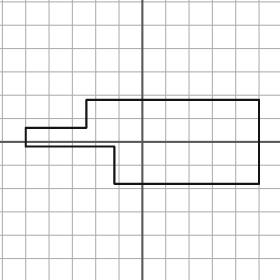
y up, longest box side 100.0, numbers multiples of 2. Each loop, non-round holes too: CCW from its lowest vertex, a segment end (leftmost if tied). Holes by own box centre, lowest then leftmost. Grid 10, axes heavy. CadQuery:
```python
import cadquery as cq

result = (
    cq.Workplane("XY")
    .moveTo(-12.0, -18.0)
    .lineTo(50.0, -18.0)
    .lineTo(50.0, 18.0)
    .lineTo(-24.0, 18.0)
    .lineTo(-24.0, 6.0)
    .lineTo(-50.0, 6.0)
    .lineTo(-50.0, -2.0)
    .lineTo(-12.0, -2.0)
    .close()
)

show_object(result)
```